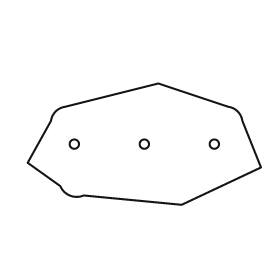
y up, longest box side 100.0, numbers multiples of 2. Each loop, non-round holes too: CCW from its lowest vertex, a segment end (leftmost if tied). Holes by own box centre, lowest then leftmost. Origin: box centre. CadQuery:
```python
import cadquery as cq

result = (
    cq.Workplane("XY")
    .moveTo(16.0, -26.0)
    .lineTo(50.0, -10.0)
    .lineTo(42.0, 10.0)
    .threePointArc((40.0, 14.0), (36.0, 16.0))
    .lineTo(6.0, 26.0)
    .lineTo(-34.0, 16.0)
    .threePointArc((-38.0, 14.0), (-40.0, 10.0))
    .lineTo(-50.0, -8.0)
    .lineTo(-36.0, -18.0)
    .threePointArc((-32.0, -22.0), (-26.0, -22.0))
    .close()
    .moveTo(-30.0, 0.0)
    .circle(2.0)
    .moveTo(0.0, 0.0)
    .circle(2.0)
    .moveTo(30.0, 0.0)
    .circle(2.0)
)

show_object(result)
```